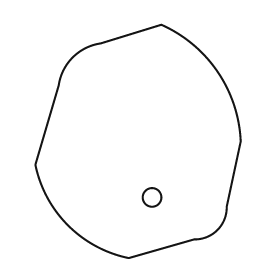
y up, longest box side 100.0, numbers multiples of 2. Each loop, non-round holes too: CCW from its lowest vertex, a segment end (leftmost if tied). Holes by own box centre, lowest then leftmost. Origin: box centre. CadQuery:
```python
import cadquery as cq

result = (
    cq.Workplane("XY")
    .moveTo(-4.0, -50.0)
    .lineTo(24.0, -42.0)
    .threePointArc((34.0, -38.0), (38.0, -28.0))
    .lineTo(44.0, 0.0)
    .threePointArc((34.0, 30.0), (10.0, 50.0))
    .lineTo(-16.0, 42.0)
    .threePointArc((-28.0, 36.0), (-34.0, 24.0))
    .lineTo(-44.0, -10.0)
    .threePointArc((-30.0, -36.0), (-4.0, -50.0))
    .close()
    .moveTo(6.0, -24.0)
    .circle(4.0)
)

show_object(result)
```